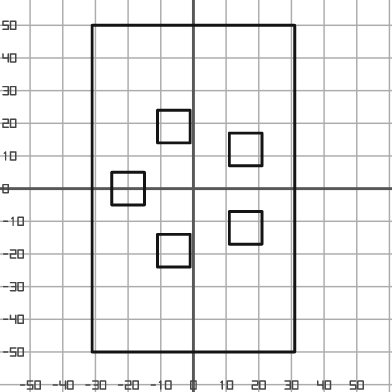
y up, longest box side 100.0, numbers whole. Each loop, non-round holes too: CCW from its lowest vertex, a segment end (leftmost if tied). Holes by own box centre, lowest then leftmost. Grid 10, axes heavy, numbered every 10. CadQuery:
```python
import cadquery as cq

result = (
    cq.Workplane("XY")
    .moveTo(-31.0, -50.0)
    .lineTo(31.0, -50.0)
    .lineTo(31.0, 50.0)
    .lineTo(-31.0, 50.0)
    .close()
    .moveTo(-11.0, -24.0)
    .lineTo(-1.0, -24.0)
    .lineTo(-1.0, -14.0)
    .lineTo(-11.0, -14.0)
    .close()
    .moveTo(11.0, -17.0)
    .lineTo(21.0, -17.0)
    .lineTo(21.0, -7.0)
    .lineTo(11.0, -7.0)
    .close()
    .moveTo(-25.0, -5.0)
    .lineTo(-15.0, -5.0)
    .lineTo(-15.0, 5.0)
    .lineTo(-25.0, 5.0)
    .close()
    .moveTo(11.0, 7.0)
    .lineTo(21.0, 7.0)
    .lineTo(21.0, 17.0)
    .lineTo(11.0, 17.0)
    .close()
    .moveTo(-11.0, 14.0)
    .lineTo(-1.0, 14.0)
    .lineTo(-1.0, 24.0)
    .lineTo(-11.0, 24.0)
    .close()
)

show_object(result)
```